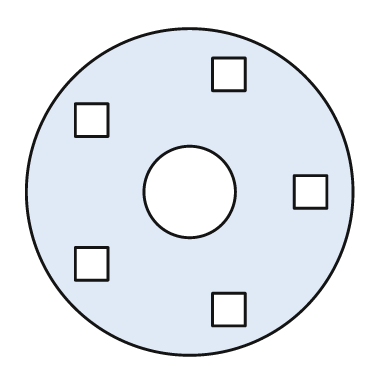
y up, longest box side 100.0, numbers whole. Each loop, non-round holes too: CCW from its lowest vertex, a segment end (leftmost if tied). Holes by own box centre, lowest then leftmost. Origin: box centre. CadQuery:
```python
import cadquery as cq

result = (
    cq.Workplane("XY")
    .moveTo(0.0, 0.0)
    .circle(50.0)
    .moveTo(7.0, -41.0)
    .lineTo(17.0, -41.0)
    .lineTo(17.0, -31.0)
    .lineTo(7.0, -31.0)
    .close()
    .moveTo(-35.0, -27.0)
    .lineTo(-25.0, -27.0)
    .lineTo(-25.0, -17.0)
    .lineTo(-35.0, -17.0)
    .close()
    .moveTo(0.0, 0.0)
    .circle(14.0)
    .moveTo(32.0, -5.0)
    .lineTo(42.0, -5.0)
    .lineTo(42.0, 5.0)
    .lineTo(32.0, 5.0)
    .close()
    .moveTo(-35.0, 17.0)
    .lineTo(-25.0, 17.0)
    .lineTo(-25.0, 27.0)
    .lineTo(-35.0, 27.0)
    .close()
    .moveTo(7.0, 31.0)
    .lineTo(17.0, 31.0)
    .lineTo(17.0, 41.0)
    .lineTo(7.0, 41.0)
    .close()
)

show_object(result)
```